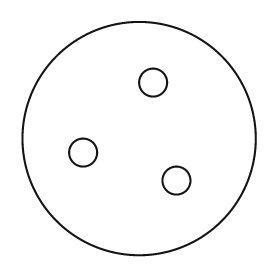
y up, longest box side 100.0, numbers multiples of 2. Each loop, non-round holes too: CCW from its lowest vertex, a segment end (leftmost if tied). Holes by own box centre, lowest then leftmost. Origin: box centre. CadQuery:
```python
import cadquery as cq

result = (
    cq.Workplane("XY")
    .moveTo(0.0, 0.0)
    .circle(50.0)
    .moveTo(16.0, -18.0)
    .circle(6.0)
    .moveTo(-24.0, -6.0)
    .circle(6.0)
    .moveTo(6.0, 24.0)
    .circle(6.0)
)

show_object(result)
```